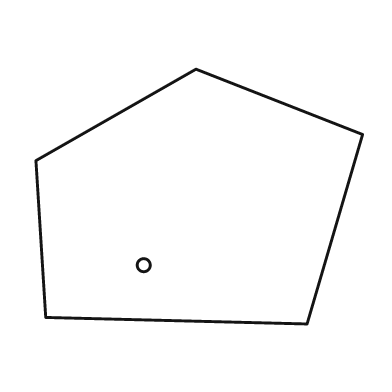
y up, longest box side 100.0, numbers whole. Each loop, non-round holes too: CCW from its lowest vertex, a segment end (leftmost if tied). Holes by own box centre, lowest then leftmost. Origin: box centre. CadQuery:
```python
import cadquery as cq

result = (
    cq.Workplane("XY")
    .moveTo(33.0, -39.0)
    .lineTo(50.0, 19.0)
    .lineTo(-1.0, 39.0)
    .lineTo(-50.0, 11.0)
    .lineTo(-47.0, -37.0)
    .close()
    .moveTo(-17.0, -21.0)
    .circle(2.0)
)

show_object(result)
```